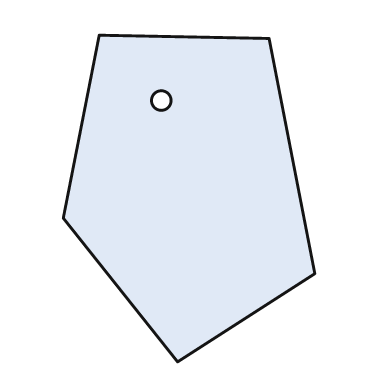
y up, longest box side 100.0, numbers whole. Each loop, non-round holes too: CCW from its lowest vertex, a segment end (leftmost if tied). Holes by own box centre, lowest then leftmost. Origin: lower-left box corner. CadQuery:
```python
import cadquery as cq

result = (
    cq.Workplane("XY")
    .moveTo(35.0, 0.0)
    .lineTo(77.0, 27.0)
    .lineTo(63.0, 99.0)
    .lineTo(11.0, 100.0)
    .lineTo(0.0, 44.0)
    .close()
    .moveTo(30.0, 80.0)
    .circle(3.0)
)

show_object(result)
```